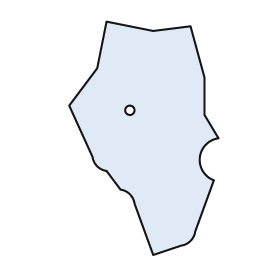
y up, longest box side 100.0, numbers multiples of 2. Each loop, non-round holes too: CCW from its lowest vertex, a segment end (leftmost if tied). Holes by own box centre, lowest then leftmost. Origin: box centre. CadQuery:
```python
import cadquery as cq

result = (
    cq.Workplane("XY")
    .moveTo(4.0, -50.0)
    .lineTo(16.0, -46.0)
    .threePointArc((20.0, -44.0), (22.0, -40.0))
    .lineTo(30.0, -18.0)
    .threePointArc((24.0, -8.0), (32.0, 0.0))
    .lineTo(26.0, 10.0)
    .lineTo(26.0, 26.0)
    .lineTo(20.0, 48.0)
    .lineTo(4.0, 46.0)
    .lineTo(-16.0, 50.0)
    .lineTo(-20.0, 30.0)
    .lineTo(-32.0, 14.0)
    .lineTo(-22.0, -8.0)
    .threePointArc((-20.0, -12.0), (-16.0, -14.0))
    .lineTo(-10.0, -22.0)
    .threePointArc((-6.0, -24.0), (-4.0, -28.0))
    .close()
    .moveTo(-6.0, 12.0)
    .circle(2.0)
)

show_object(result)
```